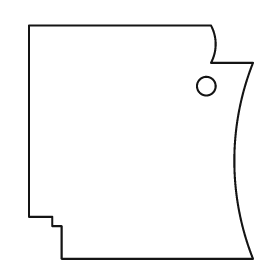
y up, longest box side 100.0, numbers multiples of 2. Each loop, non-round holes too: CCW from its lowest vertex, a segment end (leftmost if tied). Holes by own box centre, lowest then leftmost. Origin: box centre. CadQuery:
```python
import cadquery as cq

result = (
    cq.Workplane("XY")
    .moveTo(-34.0, -50.0)
    .lineTo(48.0, -50.0)
    .threePointArc((40.0, -8.0), (48.0, 34.0))
    .lineTo(30.0, 34.0)
    .threePointArc((32.0, 42.0), (30.0, 50.0))
    .lineTo(-48.0, 50.0)
    .lineTo(-48.0, -32.0)
    .lineTo(-38.0, -32.0)
    .lineTo(-38.0, -36.0)
    .lineTo(-34.0, -36.0)
    .close()
    .moveTo(28.0, 24.0)
    .circle(4.0)
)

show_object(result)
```